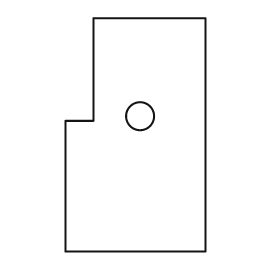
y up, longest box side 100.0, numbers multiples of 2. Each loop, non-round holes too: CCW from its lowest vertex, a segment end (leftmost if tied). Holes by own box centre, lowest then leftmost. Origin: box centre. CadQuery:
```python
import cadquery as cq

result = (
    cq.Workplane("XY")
    .moveTo(-30.0, -50.0)
    .lineTo(30.0, -50.0)
    .lineTo(30.0, 50.0)
    .lineTo(-18.0, 50.0)
    .lineTo(-18.0, 6.0)
    .lineTo(-30.0, 6.0)
    .close()
    .moveTo(2.0, 8.0)
    .circle(6.0)
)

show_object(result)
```